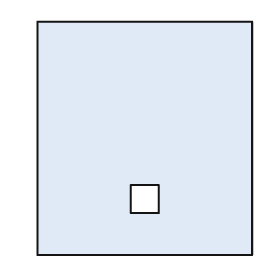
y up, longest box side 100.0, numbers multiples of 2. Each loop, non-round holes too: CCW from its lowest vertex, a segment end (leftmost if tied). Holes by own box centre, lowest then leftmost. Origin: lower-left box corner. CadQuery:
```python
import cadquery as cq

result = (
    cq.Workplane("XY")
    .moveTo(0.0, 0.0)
    .lineTo(92.0, 0.0)
    .lineTo(92.0, 100.0)
    .lineTo(0.0, 100.0)
    .close()
    .moveTo(40.0, 18.0)
    .lineTo(52.0, 18.0)
    .lineTo(52.0, 30.0)
    .lineTo(40.0, 30.0)
    .close()
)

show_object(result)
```